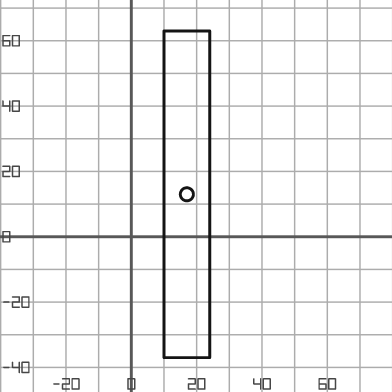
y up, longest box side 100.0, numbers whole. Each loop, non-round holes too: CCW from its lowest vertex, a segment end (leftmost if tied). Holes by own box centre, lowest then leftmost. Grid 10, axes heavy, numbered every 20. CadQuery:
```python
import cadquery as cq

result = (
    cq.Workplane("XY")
    .moveTo(10.0, -37.0)
    .lineTo(24.0, -37.0)
    .lineTo(24.0, 63.0)
    .lineTo(10.0, 63.0)
    .close()
    .moveTo(17.0, 13.0)
    .circle(2.0)
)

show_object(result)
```